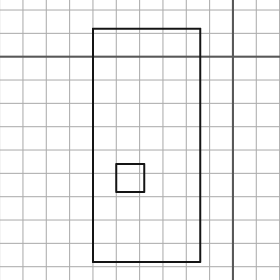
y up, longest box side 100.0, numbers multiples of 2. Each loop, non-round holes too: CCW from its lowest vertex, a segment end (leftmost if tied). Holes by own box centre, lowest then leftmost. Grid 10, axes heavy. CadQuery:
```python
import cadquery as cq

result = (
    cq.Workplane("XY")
    .moveTo(-60.0, -88.0)
    .lineTo(-14.0, -88.0)
    .lineTo(-14.0, 12.0)
    .lineTo(-60.0, 12.0)
    .close()
    .moveTo(-50.0, -58.0)
    .lineTo(-38.0, -58.0)
    .lineTo(-38.0, -46.0)
    .lineTo(-50.0, -46.0)
    .close()
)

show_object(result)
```